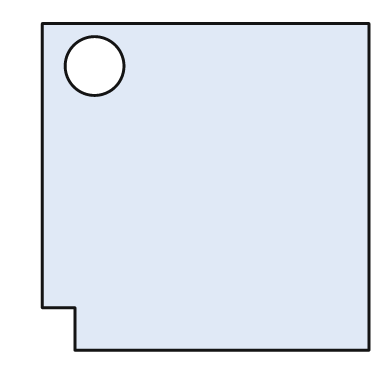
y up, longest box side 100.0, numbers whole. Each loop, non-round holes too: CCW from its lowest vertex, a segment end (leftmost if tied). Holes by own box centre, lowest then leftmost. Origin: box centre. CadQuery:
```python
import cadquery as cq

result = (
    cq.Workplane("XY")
    .moveTo(-40.0, -50.0)
    .lineTo(50.0, -50.0)
    .lineTo(50.0, 50.0)
    .lineTo(-50.0, 50.0)
    .lineTo(-50.0, -37.0)
    .lineTo(-40.0, -37.0)
    .close()
    .moveTo(-34.0, 37.0)
    .circle(9.0)
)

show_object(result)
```